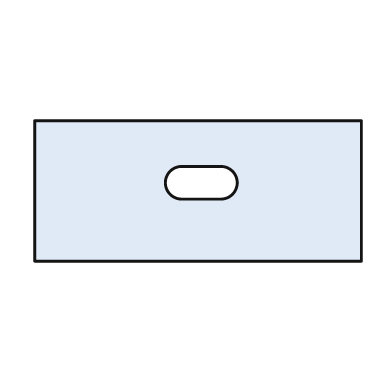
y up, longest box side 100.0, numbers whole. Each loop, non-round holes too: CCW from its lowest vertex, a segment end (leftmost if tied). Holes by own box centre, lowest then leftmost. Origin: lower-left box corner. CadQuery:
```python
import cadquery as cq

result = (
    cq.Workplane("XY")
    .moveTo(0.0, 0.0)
    .lineTo(100.0, 0.0)
    .lineTo(100.0, 43.0)
    .lineTo(0.0, 43.0)
    .close()
    .moveTo(45.0, 19.0)
    .lineTo(57.0, 19.0)
    .threePointArc((62.0, 24.0), (57.0, 29.0))
    .lineTo(45.0, 29.0)
    .threePointArc((40.0, 24.0), (45.0, 19.0))
    .close()
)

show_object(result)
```